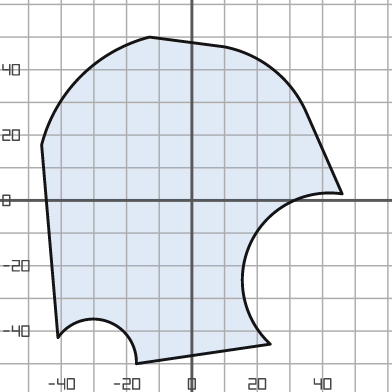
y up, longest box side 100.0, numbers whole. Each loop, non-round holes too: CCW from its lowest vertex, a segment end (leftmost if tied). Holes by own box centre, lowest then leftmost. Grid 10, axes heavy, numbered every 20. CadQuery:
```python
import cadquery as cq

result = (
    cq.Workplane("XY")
    .moveTo(-17.0, -50.0)
    .lineTo(24.0, -44.0)
    .threePointArc((18.0, -13.0), (46.0, 2.0))
    .lineTo(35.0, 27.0)
    .threePointArc((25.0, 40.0), (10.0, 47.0))
    .lineTo(-13.0, 50.0)
    .threePointArc((-34.0, 38.0), (-46.0, 17.0))
    .lineTo(-41.0, -42.0)
    .threePointArc((-26.0, -37.0), (-17.0, -50.0))
    .close()
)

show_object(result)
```